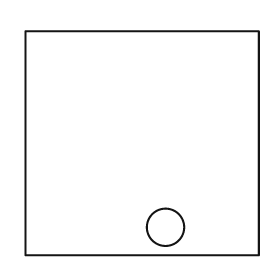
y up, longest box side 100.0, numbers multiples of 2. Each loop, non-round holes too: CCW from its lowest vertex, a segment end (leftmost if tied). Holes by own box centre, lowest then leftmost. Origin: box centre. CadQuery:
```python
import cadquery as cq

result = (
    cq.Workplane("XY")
    .moveTo(-50.0, -48.0)
    .lineTo(50.0, -48.0)
    .lineTo(50.0, 48.0)
    .lineTo(-50.0, 48.0)
    .close()
    .moveTo(10.0, -36.0)
    .circle(8.0)
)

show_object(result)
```